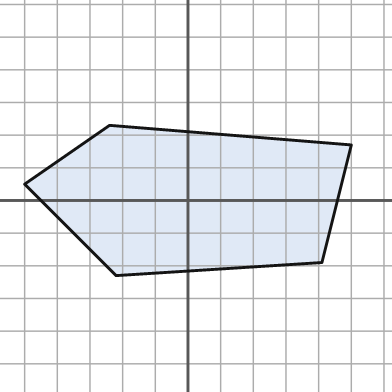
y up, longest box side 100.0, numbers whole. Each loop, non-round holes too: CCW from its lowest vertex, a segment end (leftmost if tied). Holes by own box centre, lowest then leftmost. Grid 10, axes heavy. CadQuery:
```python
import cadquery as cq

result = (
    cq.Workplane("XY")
    .moveTo(-22.0, -23.0)
    .lineTo(41.0, -19.0)
    .lineTo(50.0, 17.0)
    .lineTo(-24.0, 23.0)
    .lineTo(-50.0, 5.0)
    .close()
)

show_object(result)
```